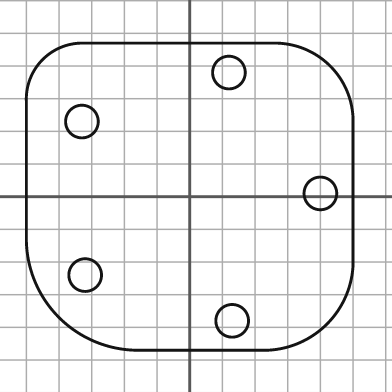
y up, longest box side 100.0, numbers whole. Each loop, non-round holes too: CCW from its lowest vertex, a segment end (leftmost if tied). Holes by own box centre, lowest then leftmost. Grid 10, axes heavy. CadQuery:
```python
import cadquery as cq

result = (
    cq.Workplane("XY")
    .moveTo(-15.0, -47.0)
    .lineTo(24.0, -47.0)
    .threePointArc((42.0, -39.0), (50.0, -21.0))
    .lineTo(50.0, 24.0)
    .threePointArc((43.0, 40.0), (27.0, 47.0))
    .lineTo(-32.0, 47.0)
    .threePointArc((-45.0, 42.0), (-50.0, 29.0))
    .lineTo(-50.0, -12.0)
    .threePointArc((-40.0, -37.0), (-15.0, -47.0))
    .close()
    .moveTo(13.0, -38.0)
    .circle(5.0)
    .moveTo(-32.0, -24.0)
    .circle(5.0)
    .moveTo(40.0, 1.0)
    .circle(5.0)
    .moveTo(-33.0, 23.0)
    .circle(5.0)
    .moveTo(12.0, 38.0)
    .circle(5.0)
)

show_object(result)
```